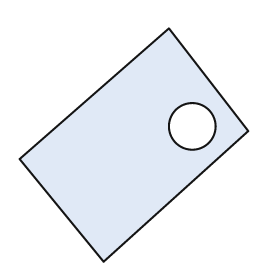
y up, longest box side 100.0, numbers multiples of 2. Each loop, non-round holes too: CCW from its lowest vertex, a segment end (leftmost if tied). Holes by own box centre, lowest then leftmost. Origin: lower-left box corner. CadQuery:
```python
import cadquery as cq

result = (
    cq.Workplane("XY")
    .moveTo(36.0, 0.0)
    .lineTo(98.0, 56.0)
    .lineTo(64.0, 100.0)
    .lineTo(0.0, 44.0)
    .close()
    .moveTo(74.0, 58.0)
    .circle(10.0)
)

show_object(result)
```